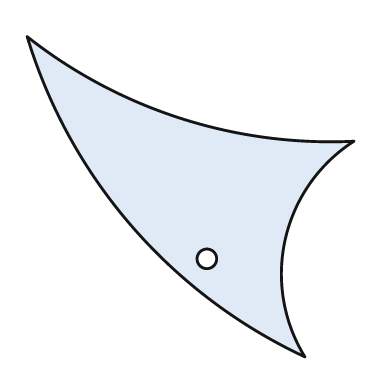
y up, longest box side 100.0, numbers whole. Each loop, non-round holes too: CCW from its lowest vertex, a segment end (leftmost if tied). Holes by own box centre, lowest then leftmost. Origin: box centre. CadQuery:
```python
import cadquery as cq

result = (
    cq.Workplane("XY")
    .moveTo(35.0, -49.0)
    .threePointArc((29.0, -13.0), (50.0, 17.0))
    .threePointArc((-3.0, 24.0), (-50.0, 49.0))
    .threePointArc((-18.0, -9.0), (35.0, -49.0))
    .close()
    .moveTo(5.0, -19.0)
    .circle(3.0)
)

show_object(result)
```